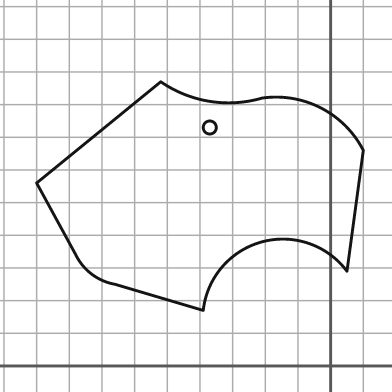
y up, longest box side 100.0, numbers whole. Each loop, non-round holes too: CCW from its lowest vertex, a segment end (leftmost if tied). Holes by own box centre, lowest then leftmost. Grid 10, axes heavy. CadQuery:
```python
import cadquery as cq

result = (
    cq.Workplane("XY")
    .moveTo(-39.0, 17.0)
    .threePointArc((-21.0, 38.0), (5.0, 29.0))
    .lineTo(10.0, 66.0)
    .threePointArc((-3.0, 79.0), (-21.0, 82.0))
    .threePointArc((-37.0, 81.0), (-52.0, 87.0))
    .lineTo(-90.0, 56.0)
    .lineTo(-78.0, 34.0)
    .threePointArc((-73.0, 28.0), (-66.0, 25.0))
    .close()
    .moveTo(-37.0, 73.0)
    .circle(2.0)
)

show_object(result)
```